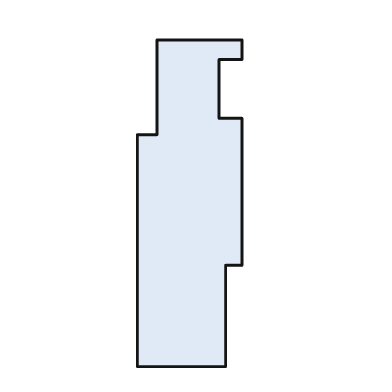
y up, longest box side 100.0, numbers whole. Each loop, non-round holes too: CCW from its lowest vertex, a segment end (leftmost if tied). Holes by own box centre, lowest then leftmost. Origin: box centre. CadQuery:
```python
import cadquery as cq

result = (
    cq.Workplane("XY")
    .moveTo(-16.0, -50.0)
    .lineTo(11.0, -50.0)
    .lineTo(11.0, -19.0)
    .lineTo(16.0, -19.0)
    .lineTo(16.0, 26.0)
    .lineTo(9.0, 26.0)
    .lineTo(9.0, 44.0)
    .lineTo(16.0, 44.0)
    .lineTo(16.0, 50.0)
    .lineTo(-10.0, 50.0)
    .lineTo(-10.0, 21.0)
    .lineTo(-16.0, 21.0)
    .close()
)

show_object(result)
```